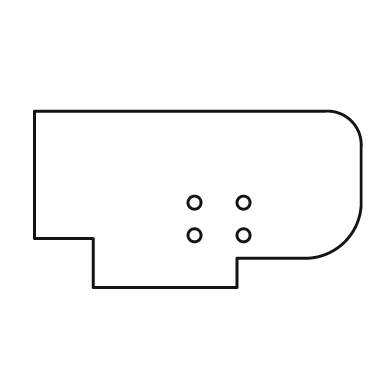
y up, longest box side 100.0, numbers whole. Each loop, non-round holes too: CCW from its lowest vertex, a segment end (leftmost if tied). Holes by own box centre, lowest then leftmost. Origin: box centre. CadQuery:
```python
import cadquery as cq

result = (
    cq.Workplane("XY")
    .moveTo(-32.0, -27.0)
    .lineTo(12.0, -27.0)
    .lineTo(12.0, -18.0)
    .lineTo(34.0, -18.0)
    .threePointArc((45.0, -13.0), (50.0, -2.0))
    .lineTo(50.0, 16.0)
    .threePointArc((47.0, 24.0), (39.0, 27.0))
    .lineTo(-50.0, 27.0)
    .lineTo(-50.0, -12.0)
    .lineTo(-32.0, -12.0)
    .close()
    .moveTo(-1.0, -11.0)
    .circle(2.0)
    .moveTo(14.0, -11.0)
    .circle(2.0)
    .moveTo(-1.0, -1.0)
    .circle(2.0)
    .moveTo(14.0, -1.0)
    .circle(2.0)
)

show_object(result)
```